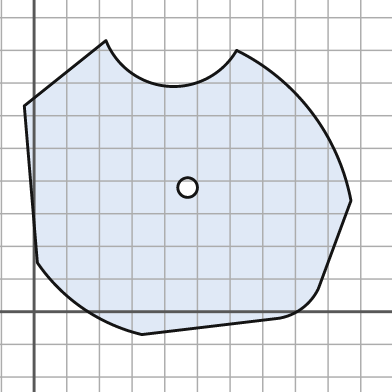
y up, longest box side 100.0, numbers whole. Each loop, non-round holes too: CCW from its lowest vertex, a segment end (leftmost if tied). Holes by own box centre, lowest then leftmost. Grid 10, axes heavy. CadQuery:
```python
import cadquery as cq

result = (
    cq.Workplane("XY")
    .moveTo(33.0, -7.0)
    .lineTo(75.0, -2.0)
    .threePointArc((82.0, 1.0), (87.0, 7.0))
    .lineTo(97.0, 34.0)
    .threePointArc((85.0, 61.0), (62.0, 80.0))
    .threePointArc((41.0, 69.0), (22.0, 83.0))
    .lineTo(-3.0, 63.0)
    .lineTo(1.0, 15.0)
    .threePointArc((15.0, 1.0), (33.0, -7.0))
    .close()
    .moveTo(47.0, 38.0)
    .circle(3.0)
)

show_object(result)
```